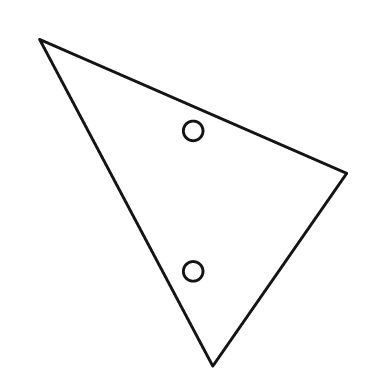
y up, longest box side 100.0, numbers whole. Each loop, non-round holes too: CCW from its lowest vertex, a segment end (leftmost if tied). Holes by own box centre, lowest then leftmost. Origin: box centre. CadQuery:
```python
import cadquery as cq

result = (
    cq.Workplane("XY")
    .moveTo(6.0, -50.0)
    .lineTo(47.0, 9.0)
    .lineTo(-47.0, 50.0)
    .close()
    .moveTo(0.0, -21.0)
    .circle(3.0)
    .moveTo(0.0, 22.0)
    .circle(3.0)
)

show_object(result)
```